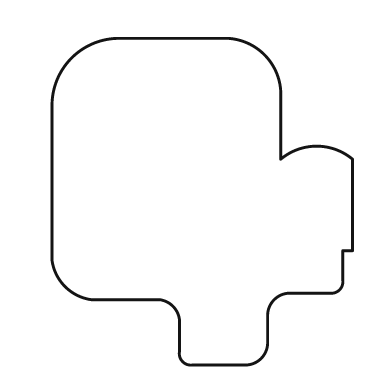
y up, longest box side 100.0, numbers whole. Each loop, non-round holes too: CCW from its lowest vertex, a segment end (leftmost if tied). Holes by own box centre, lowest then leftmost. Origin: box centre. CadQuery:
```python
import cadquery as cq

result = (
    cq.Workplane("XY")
    .moveTo(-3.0, -50.0)
    .lineTo(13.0, -50.0)
    .threePointArc((18.0, -48.0), (20.0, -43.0))
    .lineTo(20.0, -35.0)
    .threePointArc((22.0, -30.0), (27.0, -28.0))
    .lineTo(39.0, -28.0)
    .threePointArc((42.0, -27.0), (43.0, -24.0))
    .lineTo(43.0, -15.0)
    .lineTo(46.0, -15.0)
    .lineTo(46.0, 13.0)
    .threePointArc((35.0, 17.0), (24.0, 13.0))
    .lineTo(24.0, 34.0)
    .threePointArc((19.0, 45.0), (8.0, 50.0))
    .lineTo(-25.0, 50.0)
    .threePointArc((-40.0, 44.0), (-46.0, 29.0))
    .lineTo(-46.0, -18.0)
    .threePointArc((-42.0, -26.0), (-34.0, -30.0))
    .lineTo(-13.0, -30.0)
    .threePointArc((-9.0, -32.0), (-7.0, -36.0))
    .lineTo(-7.0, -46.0)
    .threePointArc((-6.0, -49.0), (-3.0, -50.0))
    .close()
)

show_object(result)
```